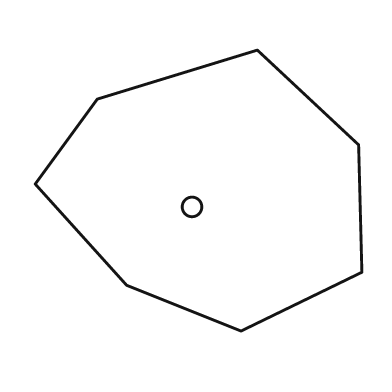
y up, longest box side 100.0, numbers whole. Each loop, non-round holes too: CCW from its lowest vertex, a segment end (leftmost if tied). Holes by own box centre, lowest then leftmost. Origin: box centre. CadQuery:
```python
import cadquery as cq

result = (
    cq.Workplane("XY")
    .moveTo(13.0, -43.0)
    .lineTo(50.0, -25.0)
    .lineTo(49.0, 14.0)
    .lineTo(18.0, 43.0)
    .lineTo(-31.0, 28.0)
    .lineTo(-50.0, 2.0)
    .lineTo(-22.0, -29.0)
    .close()
    .moveTo(-2.0, -5.0)
    .circle(3.0)
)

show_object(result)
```